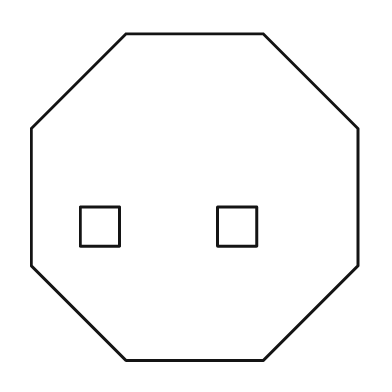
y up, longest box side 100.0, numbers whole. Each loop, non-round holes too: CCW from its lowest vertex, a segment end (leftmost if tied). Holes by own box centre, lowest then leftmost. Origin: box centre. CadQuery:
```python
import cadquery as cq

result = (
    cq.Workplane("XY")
    .moveTo(-21.0, -50.0)
    .lineTo(21.0, -50.0)
    .lineTo(50.0, -21.0)
    .lineTo(50.0, 21.0)
    .lineTo(21.0, 50.0)
    .lineTo(-21.0, 50.0)
    .lineTo(-50.0, 21.0)
    .lineTo(-50.0, -21.0)
    .close()
    .moveTo(-35.0, -15.0)
    .lineTo(-23.0, -15.0)
    .lineTo(-23.0, -3.0)
    .lineTo(-35.0, -3.0)
    .close()
    .moveTo(7.0, -15.0)
    .lineTo(19.0, -15.0)
    .lineTo(19.0, -3.0)
    .lineTo(7.0, -3.0)
    .close()
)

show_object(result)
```